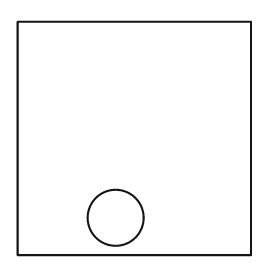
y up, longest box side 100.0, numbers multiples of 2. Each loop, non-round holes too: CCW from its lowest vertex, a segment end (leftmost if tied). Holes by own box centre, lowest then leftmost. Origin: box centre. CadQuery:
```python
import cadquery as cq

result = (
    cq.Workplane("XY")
    .moveTo(-50.0, -50.0)
    .lineTo(50.0, -50.0)
    .lineTo(50.0, 50.0)
    .lineTo(-50.0, 50.0)
    .close()
    .moveTo(-8.0, -34.0)
    .circle(12.0)
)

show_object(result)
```